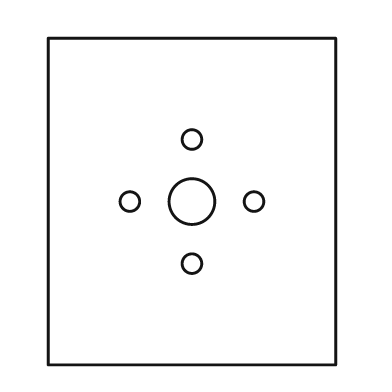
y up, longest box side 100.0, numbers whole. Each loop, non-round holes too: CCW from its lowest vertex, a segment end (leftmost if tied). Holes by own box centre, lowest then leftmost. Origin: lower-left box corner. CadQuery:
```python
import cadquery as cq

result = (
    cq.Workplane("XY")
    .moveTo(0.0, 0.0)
    .lineTo(88.0, 0.0)
    .lineTo(88.0, 100.0)
    .lineTo(0.0, 100.0)
    .close()
    .moveTo(44.0, 31.0)
    .circle(3.0)
    .moveTo(25.0, 50.0)
    .circle(3.0)
    .moveTo(44.0, 50.0)
    .circle(7.0)
    .moveTo(63.0, 50.0)
    .circle(3.0)
    .moveTo(44.0, 69.0)
    .circle(3.0)
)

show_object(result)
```